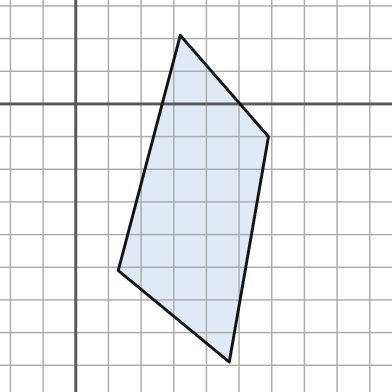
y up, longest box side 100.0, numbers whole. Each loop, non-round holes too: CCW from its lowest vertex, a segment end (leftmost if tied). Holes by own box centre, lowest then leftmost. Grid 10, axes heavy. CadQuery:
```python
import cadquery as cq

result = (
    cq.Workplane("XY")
    .moveTo(47.0, -79.0)
    .lineTo(59.0, -10.0)
    .lineTo(32.0, 21.0)
    .lineTo(13.0, -51.0)
    .close()
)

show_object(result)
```